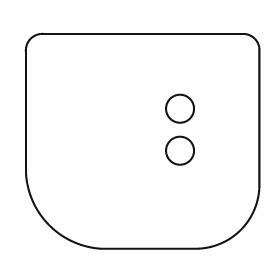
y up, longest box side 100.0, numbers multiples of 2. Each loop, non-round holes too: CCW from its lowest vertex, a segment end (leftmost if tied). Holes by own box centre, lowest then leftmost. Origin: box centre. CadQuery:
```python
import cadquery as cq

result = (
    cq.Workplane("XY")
    .moveTo(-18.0, -46.0)
    .lineTo(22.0, -46.0)
    .threePointArc((42.0, -38.0), (50.0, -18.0))
    .lineTo(50.0, 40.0)
    .threePointArc((48.0, 44.0), (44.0, 46.0))
    .lineTo(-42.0, 46.0)
    .threePointArc((-48.0, 44.0), (-50.0, 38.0))
    .lineTo(-50.0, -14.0)
    .threePointArc((-40.0, -36.0), (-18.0, -46.0))
    .close()
    .moveTo(16.0, -4.0)
    .circle(6.0)
    .moveTo(16.0, 14.0)
    .circle(6.0)
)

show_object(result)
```